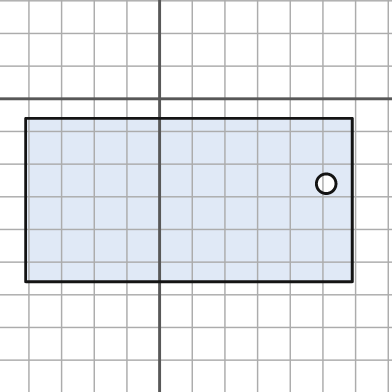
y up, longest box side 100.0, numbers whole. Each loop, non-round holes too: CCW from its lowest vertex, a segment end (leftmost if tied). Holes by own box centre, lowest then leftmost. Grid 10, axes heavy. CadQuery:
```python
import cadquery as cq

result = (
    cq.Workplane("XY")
    .moveTo(-41.0, -56.0)
    .lineTo(59.0, -56.0)
    .lineTo(59.0, -6.0)
    .lineTo(-41.0, -6.0)
    .close()
    .moveTo(51.0, -26.0)
    .circle(3.0)
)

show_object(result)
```